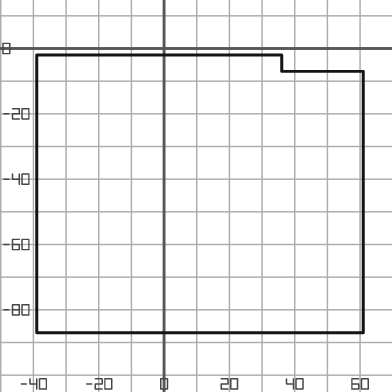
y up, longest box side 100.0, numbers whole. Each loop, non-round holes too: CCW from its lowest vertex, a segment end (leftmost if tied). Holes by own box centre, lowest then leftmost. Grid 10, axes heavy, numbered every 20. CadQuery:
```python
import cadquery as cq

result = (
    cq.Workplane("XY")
    .moveTo(-39.0, -87.0)
    .lineTo(61.0, -87.0)
    .lineTo(61.0, -7.0)
    .lineTo(36.0, -7.0)
    .lineTo(36.0, -2.0)
    .lineTo(-39.0, -2.0)
    .close()
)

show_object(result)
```